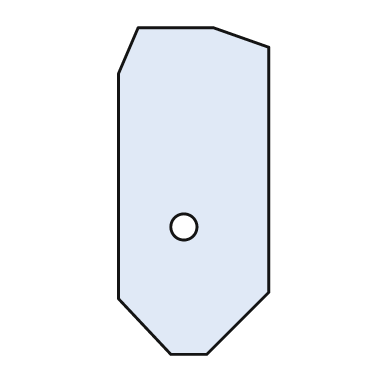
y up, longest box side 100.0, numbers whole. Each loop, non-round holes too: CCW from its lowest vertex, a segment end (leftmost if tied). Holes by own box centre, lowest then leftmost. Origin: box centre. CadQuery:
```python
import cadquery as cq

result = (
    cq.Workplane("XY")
    .moveTo(-7.0, -50.0)
    .lineTo(4.0, -50.0)
    .lineTo(23.0, -31.0)
    .lineTo(23.0, 44.0)
    .lineTo(6.0, 50.0)
    .lineTo(-17.0, 50.0)
    .lineTo(-23.0, 36.0)
    .lineTo(-23.0, -33.0)
    .close()
    .moveTo(-3.0, -11.0)
    .circle(4.0)
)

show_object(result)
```